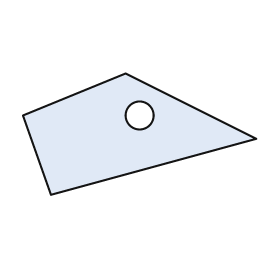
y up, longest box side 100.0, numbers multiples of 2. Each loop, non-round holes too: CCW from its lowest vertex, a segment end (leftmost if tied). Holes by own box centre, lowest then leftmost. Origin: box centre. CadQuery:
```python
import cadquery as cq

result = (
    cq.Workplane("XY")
    .moveTo(-38.0, -26.0)
    .lineTo(50.0, -2.0)
    .lineTo(-6.0, 26.0)
    .lineTo(-50.0, 8.0)
    .close()
    .moveTo(0.0, 8.0)
    .circle(6.0)
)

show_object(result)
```